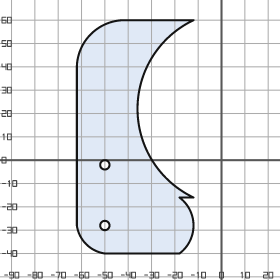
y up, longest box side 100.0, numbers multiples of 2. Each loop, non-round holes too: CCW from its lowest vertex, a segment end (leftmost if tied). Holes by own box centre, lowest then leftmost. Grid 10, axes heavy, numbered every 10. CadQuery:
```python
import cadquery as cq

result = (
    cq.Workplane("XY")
    .moveTo(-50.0, -40.0)
    .lineTo(-18.0, -40.0)
    .threePointArc((-12.0, -28.0), (-18.0, -16.0))
    .lineTo(-12.0, -16.0)
    .threePointArc((-36.0, 22.0), (-12.0, 60.0))
    .lineTo(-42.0, 60.0)
    .threePointArc((-56.0, 54.0), (-62.0, 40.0))
    .lineTo(-62.0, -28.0)
    .threePointArc((-58.0, -36.0), (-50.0, -40.0))
    .close()
    .moveTo(-50.0, -28.0)
    .circle(2.0)
    .moveTo(-50.0, -2.0)
    .circle(2.0)
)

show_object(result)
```